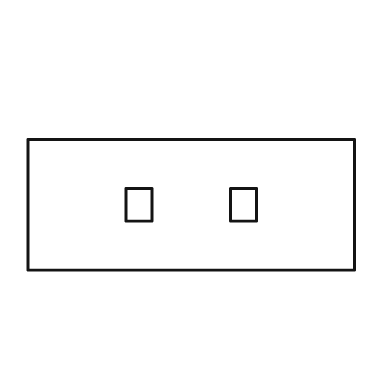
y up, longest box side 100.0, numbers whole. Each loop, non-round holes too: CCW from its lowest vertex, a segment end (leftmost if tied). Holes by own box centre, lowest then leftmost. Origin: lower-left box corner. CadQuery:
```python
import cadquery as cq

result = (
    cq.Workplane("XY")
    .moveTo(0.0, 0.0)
    .lineTo(100.0, 0.0)
    .lineTo(100.0, 40.0)
    .lineTo(0.0, 40.0)
    .close()
    .moveTo(30.0, 15.0)
    .lineTo(38.0, 15.0)
    .lineTo(38.0, 25.0)
    .lineTo(30.0, 25.0)
    .close()
    .moveTo(62.0, 15.0)
    .lineTo(70.0, 15.0)
    .lineTo(70.0, 25.0)
    .lineTo(62.0, 25.0)
    .close()
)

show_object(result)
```